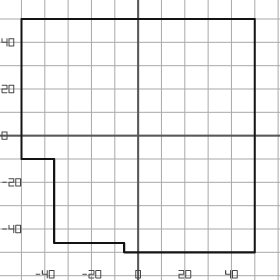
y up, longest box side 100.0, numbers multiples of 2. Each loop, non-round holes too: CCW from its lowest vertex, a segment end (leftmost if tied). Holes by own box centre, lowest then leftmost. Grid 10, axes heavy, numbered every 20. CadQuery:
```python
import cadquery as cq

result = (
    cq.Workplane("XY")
    .moveTo(-6.0, -50.0)
    .lineTo(50.0, -50.0)
    .lineTo(50.0, 50.0)
    .lineTo(-50.0, 50.0)
    .lineTo(-50.0, -10.0)
    .lineTo(-36.0, -10.0)
    .lineTo(-36.0, -46.0)
    .lineTo(-6.0, -46.0)
    .close()
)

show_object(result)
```